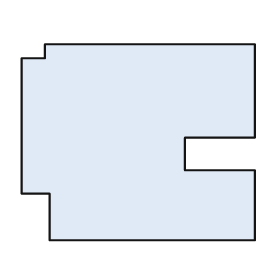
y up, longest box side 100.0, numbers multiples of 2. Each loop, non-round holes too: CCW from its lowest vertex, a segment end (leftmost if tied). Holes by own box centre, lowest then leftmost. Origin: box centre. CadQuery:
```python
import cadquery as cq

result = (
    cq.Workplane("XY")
    .moveTo(-38.0, -42.0)
    .lineTo(50.0, -42.0)
    .lineTo(50.0, -12.0)
    .lineTo(20.0, -12.0)
    .lineTo(20.0, 2.0)
    .lineTo(50.0, 2.0)
    .lineTo(50.0, 42.0)
    .lineTo(-40.0, 42.0)
    .lineTo(-40.0, 36.0)
    .lineTo(-50.0, 36.0)
    .lineTo(-50.0, -22.0)
    .lineTo(-38.0, -22.0)
    .close()
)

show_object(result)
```